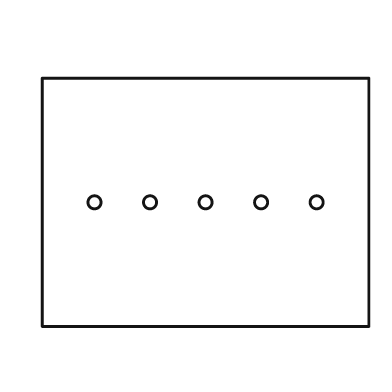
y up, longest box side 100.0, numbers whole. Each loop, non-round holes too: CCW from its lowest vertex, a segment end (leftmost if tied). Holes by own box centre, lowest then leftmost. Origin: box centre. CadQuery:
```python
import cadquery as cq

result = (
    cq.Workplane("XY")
    .moveTo(-50.0, -38.0)
    .lineTo(50.0, -38.0)
    .lineTo(50.0, 38.0)
    .lineTo(-50.0, 38.0)
    .close()
    .moveTo(-34.0, 0.0)
    .circle(2.0)
    .moveTo(-17.0, 0.0)
    .circle(2.0)
    .moveTo(0.0, 0.0)
    .circle(2.0)
    .moveTo(17.0, 0.0)
    .circle(2.0)
    .moveTo(34.0, 0.0)
    .circle(2.0)
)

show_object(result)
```